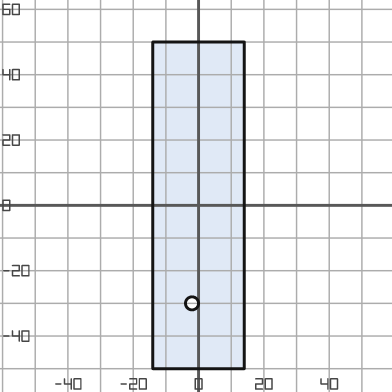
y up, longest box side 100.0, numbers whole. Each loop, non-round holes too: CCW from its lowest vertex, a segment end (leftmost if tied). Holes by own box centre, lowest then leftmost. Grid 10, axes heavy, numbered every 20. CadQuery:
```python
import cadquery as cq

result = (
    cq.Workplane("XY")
    .moveTo(-14.0, -50.0)
    .lineTo(14.0, -50.0)
    .lineTo(14.0, 50.0)
    .lineTo(-14.0, 50.0)
    .close()
    .moveTo(-2.0, -30.0)
    .circle(2.0)
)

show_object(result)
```